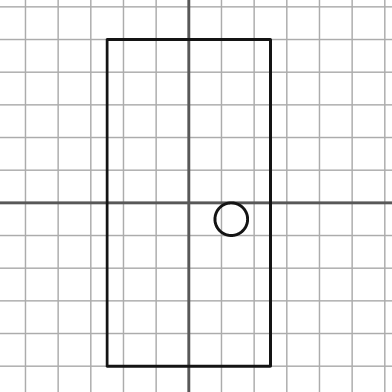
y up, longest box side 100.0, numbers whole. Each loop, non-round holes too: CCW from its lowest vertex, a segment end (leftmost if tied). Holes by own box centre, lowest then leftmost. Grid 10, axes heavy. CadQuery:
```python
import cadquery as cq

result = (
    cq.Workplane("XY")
    .moveTo(-25.0, -50.0)
    .lineTo(25.0, -50.0)
    .lineTo(25.0, 50.0)
    .lineTo(-25.0, 50.0)
    .close()
    .moveTo(13.0, -5.0)
    .circle(5.0)
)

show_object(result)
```